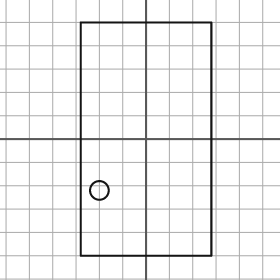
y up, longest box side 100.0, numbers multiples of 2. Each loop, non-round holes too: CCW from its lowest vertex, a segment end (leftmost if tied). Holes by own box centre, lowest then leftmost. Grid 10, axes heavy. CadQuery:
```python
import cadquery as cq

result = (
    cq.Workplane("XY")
    .moveTo(-28.0, -50.0)
    .lineTo(28.0, -50.0)
    .lineTo(28.0, 50.0)
    .lineTo(-28.0, 50.0)
    .close()
    .moveTo(-20.0, -22.0)
    .circle(4.0)
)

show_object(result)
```